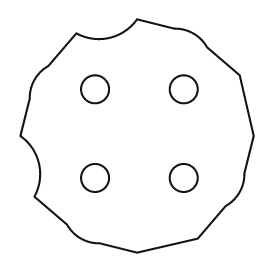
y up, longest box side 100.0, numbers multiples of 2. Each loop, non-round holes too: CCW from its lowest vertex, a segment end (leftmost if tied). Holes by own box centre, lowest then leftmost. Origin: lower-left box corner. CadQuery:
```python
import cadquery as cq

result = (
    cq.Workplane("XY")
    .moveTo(50.0, 0.0)
    .lineTo(76.0, 6.0)
    .lineTo(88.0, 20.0)
    .threePointArc((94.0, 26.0), (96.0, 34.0))
    .lineTo(100.0, 50.0)
    .lineTo(94.0, 76.0)
    .lineTo(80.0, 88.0)
    .threePointArc((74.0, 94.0), (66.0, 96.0))
    .lineTo(50.0, 100.0)
    .threePointArc((38.0, 92.0), (24.0, 94.0))
    .lineTo(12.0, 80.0)
    .threePointArc((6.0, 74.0), (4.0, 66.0))
    .lineTo(0.0, 50.0)
    .threePointArc((8.0, 38.0), (6.0, 24.0))
    .lineTo(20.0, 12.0)
    .threePointArc((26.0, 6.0), (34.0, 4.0))
    .close()
    .moveTo(32.0, 32.0)
    .circle(6.0)
    .moveTo(70.0, 32.0)
    .circle(6.0)
    .moveTo(32.0, 70.0)
    .circle(6.0)
    .moveTo(70.0, 70.0)
    .circle(6.0)
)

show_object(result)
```